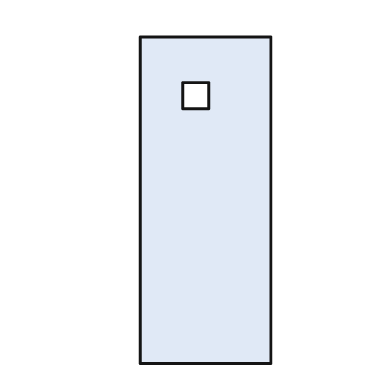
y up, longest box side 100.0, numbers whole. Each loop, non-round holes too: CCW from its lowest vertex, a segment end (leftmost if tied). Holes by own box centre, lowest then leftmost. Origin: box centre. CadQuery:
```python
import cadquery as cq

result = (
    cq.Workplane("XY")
    .moveTo(-20.0, -50.0)
    .lineTo(20.0, -50.0)
    .lineTo(20.0, 50.0)
    .lineTo(-20.0, 50.0)
    .close()
    .moveTo(-7.0, 28.0)
    .lineTo(1.0, 28.0)
    .lineTo(1.0, 36.0)
    .lineTo(-7.0, 36.0)
    .close()
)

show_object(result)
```